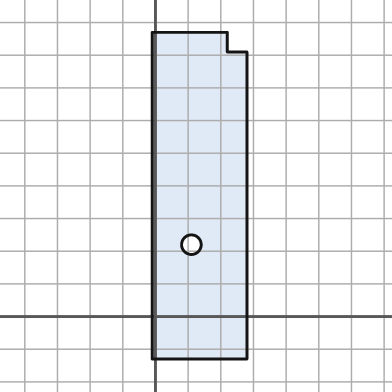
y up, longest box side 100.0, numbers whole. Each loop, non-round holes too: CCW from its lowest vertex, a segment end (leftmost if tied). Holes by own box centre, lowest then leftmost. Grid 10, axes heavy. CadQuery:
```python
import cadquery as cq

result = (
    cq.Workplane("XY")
    .moveTo(-1.0, -13.0)
    .lineTo(28.0, -13.0)
    .lineTo(28.0, 81.0)
    .lineTo(22.0, 81.0)
    .lineTo(22.0, 87.0)
    .lineTo(-1.0, 87.0)
    .close()
    .moveTo(11.0, 22.0)
    .circle(3.0)
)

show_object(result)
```